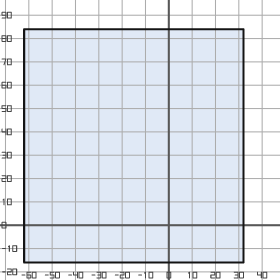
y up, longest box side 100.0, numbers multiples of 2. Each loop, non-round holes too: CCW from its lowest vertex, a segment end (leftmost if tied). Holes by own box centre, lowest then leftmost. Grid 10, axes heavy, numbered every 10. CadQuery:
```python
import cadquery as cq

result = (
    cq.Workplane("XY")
    .moveTo(-62.0, -16.0)
    .lineTo(32.0, -16.0)
    .lineTo(32.0, 84.0)
    .lineTo(-62.0, 84.0)
    .close()
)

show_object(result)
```